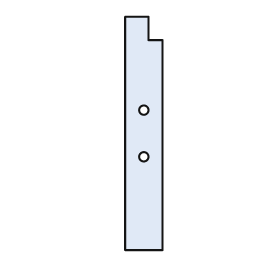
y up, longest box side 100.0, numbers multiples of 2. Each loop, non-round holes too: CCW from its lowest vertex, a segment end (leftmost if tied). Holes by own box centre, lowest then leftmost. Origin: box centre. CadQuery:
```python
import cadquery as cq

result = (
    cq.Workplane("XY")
    .moveTo(-8.0, -50.0)
    .lineTo(8.0, -50.0)
    .lineTo(8.0, 40.0)
    .lineTo(2.0, 40.0)
    .lineTo(2.0, 50.0)
    .lineTo(-8.0, 50.0)
    .close()
    .moveTo(0.0, -10.0)
    .circle(2.0)
    .moveTo(0.0, 10.0)
    .circle(2.0)
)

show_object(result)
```